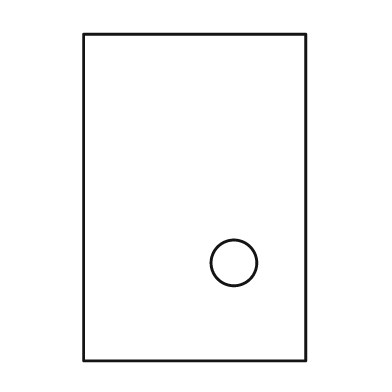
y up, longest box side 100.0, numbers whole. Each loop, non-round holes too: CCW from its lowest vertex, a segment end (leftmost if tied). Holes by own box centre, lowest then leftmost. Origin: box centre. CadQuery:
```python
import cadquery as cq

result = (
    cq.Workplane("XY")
    .moveTo(-34.0, -50.0)
    .lineTo(34.0, -50.0)
    .lineTo(34.0, 50.0)
    .lineTo(-34.0, 50.0)
    .close()
    .moveTo(12.0, -20.0)
    .circle(7.0)
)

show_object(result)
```